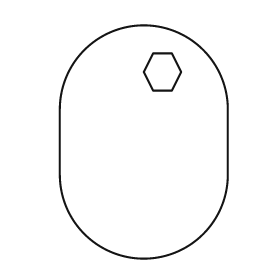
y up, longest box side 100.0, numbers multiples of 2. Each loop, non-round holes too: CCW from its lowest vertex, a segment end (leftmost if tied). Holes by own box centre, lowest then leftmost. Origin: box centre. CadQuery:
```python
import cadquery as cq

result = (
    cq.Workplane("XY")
    .moveTo(-36.0, -14.0)
    .threePointArc((0.0, -50.0), (36.0, -14.0))
    .lineTo(36.0, 14.0)
    .threePointArc((0.0, 50.0), (-36.0, 14.0))
    .close()
    .moveTo(4.0, 22.0)
    .lineTo(12.0, 22.0)
    .lineTo(16.0, 30.0)
    .lineTo(12.0, 38.0)
    .lineTo(4.0, 38.0)
    .lineTo(0.0, 30.0)
    .close()
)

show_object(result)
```